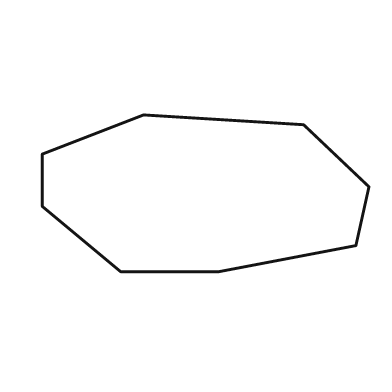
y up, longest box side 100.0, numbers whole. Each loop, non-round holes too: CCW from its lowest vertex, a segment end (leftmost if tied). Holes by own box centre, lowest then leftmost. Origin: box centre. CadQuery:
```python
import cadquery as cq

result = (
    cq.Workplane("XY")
    .moveTo(-26.0, -24.0)
    .lineTo(4.0, -24.0)
    .lineTo(46.0, -16.0)
    .lineTo(50.0, 2.0)
    .lineTo(30.0, 21.0)
    .lineTo(-19.0, 24.0)
    .lineTo(-50.0, 12.0)
    .lineTo(-50.0, -4.0)
    .close()
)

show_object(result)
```